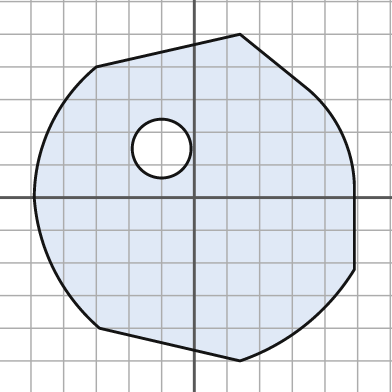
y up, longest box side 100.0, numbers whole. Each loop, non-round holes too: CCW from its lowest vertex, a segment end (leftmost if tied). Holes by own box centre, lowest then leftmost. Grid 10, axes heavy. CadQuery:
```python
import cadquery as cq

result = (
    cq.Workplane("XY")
    .moveTo(14.0, -50.0)
    .threePointArc((34.0, -39.0), (49.0, -22.0))
    .lineTo(49.0, 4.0)
    .threePointArc((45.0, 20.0), (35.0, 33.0))
    .lineTo(14.0, 50.0)
    .lineTo(-30.0, 40.0)
    .threePointArc((-44.0, 22.0), (-49.0, 0.0))
    .threePointArc((-43.0, -22.0), (-29.0, -40.0))
    .close()
    .moveTo(-10.0, 15.0)
    .circle(9.0)
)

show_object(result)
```